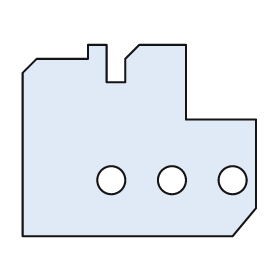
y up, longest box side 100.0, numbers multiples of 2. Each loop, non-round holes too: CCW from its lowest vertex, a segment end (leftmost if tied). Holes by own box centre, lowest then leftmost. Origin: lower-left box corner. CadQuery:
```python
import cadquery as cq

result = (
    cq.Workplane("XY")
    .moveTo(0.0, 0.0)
    .lineTo(90.0, 0.0)
    .lineTo(100.0, 12.0)
    .lineTo(100.0, 50.0)
    .lineTo(70.0, 50.0)
    .lineTo(70.0, 82.0)
    .lineTo(50.0, 82.0)
    .lineTo(44.0, 76.0)
    .lineTo(44.0, 66.0)
    .lineTo(36.0, 66.0)
    .lineTo(36.0, 82.0)
    .lineTo(28.0, 82.0)
    .lineTo(28.0, 76.0)
    .lineTo(6.0, 76.0)
    .lineTo(0.0, 70.0)
    .close()
    .moveTo(38.0, 24.0)
    .circle(6.0)
    .moveTo(64.0, 24.0)
    .circle(6.0)
    .moveTo(90.0, 24.0)
    .circle(6.0)
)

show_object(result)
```